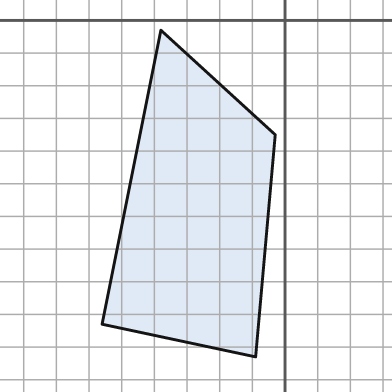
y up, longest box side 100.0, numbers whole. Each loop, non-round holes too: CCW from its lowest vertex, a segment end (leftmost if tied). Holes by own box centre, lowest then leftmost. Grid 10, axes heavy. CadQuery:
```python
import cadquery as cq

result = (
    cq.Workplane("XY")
    .moveTo(-9.0, -103.0)
    .lineTo(-3.0, -35.0)
    .lineTo(-38.0, -3.0)
    .lineTo(-56.0, -93.0)
    .close()
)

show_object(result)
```